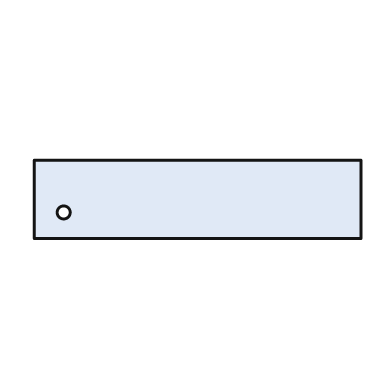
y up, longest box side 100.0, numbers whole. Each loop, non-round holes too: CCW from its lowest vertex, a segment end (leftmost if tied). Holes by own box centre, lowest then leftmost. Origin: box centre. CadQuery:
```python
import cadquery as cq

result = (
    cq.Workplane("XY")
    .moveTo(-50.0, -12.0)
    .lineTo(50.0, -12.0)
    .lineTo(50.0, 12.0)
    .lineTo(-50.0, 12.0)
    .close()
    .moveTo(-41.0, -4.0)
    .circle(2.0)
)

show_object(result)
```